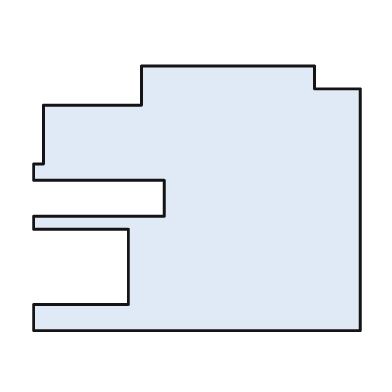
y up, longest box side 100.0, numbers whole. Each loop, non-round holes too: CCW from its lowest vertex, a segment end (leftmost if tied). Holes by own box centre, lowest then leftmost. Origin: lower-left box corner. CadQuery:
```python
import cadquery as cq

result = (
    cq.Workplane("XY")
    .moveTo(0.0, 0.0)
    .lineTo(100.0, 0.0)
    .lineTo(100.0, 74.0)
    .lineTo(86.0, 74.0)
    .lineTo(86.0, 81.0)
    .lineTo(33.0, 81.0)
    .lineTo(33.0, 69.0)
    .lineTo(3.0, 69.0)
    .lineTo(3.0, 51.0)
    .lineTo(0.0, 51.0)
    .lineTo(0.0, 46.0)
    .lineTo(40.0, 46.0)
    .lineTo(40.0, 35.0)
    .lineTo(0.0, 35.0)
    .lineTo(0.0, 31.0)
    .lineTo(29.0, 31.0)
    .lineTo(29.0, 8.0)
    .lineTo(0.0, 8.0)
    .close()
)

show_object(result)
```